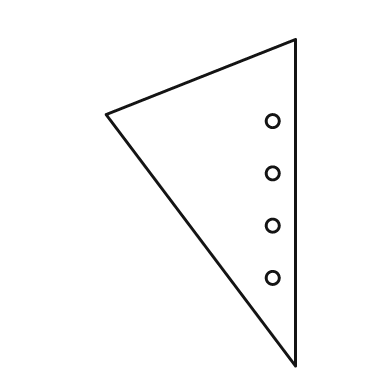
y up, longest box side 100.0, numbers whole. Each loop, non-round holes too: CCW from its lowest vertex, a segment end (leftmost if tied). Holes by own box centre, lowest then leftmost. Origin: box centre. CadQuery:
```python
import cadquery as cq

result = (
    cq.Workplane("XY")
    .moveTo(29.0, -50.0)
    .lineTo(29.0, 50.0)
    .lineTo(-29.0, 27.0)
    .close()
    .moveTo(22.0, -23.0)
    .circle(2.0)
    .moveTo(22.0, -7.0)
    .circle(2.0)
    .moveTo(22.0, 9.0)
    .circle(2.0)
    .moveTo(22.0, 25.0)
    .circle(2.0)
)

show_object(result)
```